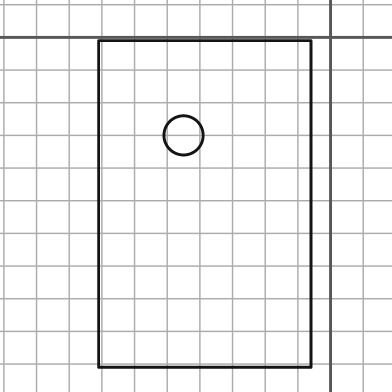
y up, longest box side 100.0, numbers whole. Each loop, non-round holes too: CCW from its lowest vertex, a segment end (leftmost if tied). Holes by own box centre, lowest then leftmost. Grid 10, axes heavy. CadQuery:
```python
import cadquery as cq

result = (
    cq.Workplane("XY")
    .moveTo(-71.0, -101.0)
    .lineTo(-6.0, -101.0)
    .lineTo(-6.0, -1.0)
    .lineTo(-71.0, -1.0)
    .close()
    .moveTo(-45.0, -30.0)
    .circle(6.0)
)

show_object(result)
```